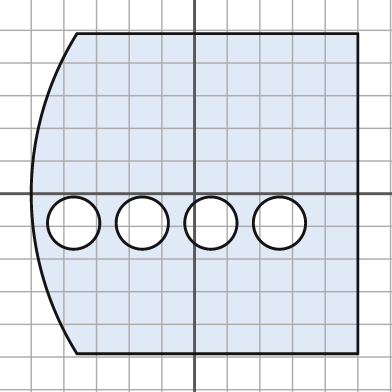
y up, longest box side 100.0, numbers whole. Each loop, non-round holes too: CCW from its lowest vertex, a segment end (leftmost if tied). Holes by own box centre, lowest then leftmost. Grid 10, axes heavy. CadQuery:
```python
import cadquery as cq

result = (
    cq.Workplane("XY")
    .moveTo(-36.0, -49.0)
    .lineTo(50.0, -49.0)
    .lineTo(50.0, 49.0)
    .lineTo(-36.0, 49.0)
    .threePointArc((-50.0, 0.0), (-36.0, -49.0))
    .close()
    .moveTo(-37.0, -9.0)
    .circle(8.0)
    .moveTo(-16.0, -9.0)
    .circle(8.0)
    .moveTo(5.0, -9.0)
    .circle(8.0)
    .moveTo(26.0, -9.0)
    .circle(8.0)
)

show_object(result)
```